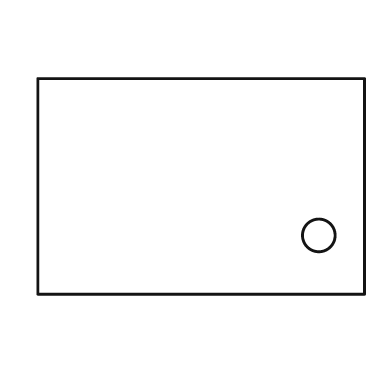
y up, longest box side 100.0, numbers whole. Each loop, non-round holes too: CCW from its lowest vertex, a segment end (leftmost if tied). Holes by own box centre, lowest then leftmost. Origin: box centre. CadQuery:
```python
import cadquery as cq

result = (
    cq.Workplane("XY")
    .moveTo(-50.0, -33.0)
    .lineTo(50.0, -33.0)
    .lineTo(50.0, 33.0)
    .lineTo(-50.0, 33.0)
    .close()
    .moveTo(36.0, -15.0)
    .circle(5.0)
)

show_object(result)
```